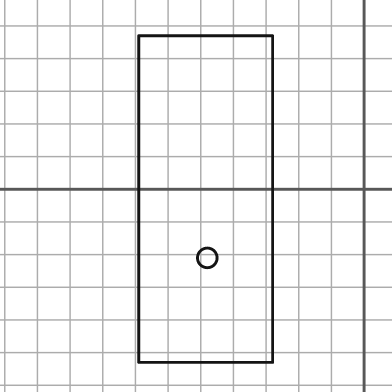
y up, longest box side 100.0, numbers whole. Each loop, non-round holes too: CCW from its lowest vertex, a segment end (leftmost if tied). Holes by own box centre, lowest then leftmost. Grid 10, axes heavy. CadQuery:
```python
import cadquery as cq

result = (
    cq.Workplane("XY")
    .moveTo(-69.0, -53.0)
    .lineTo(-28.0, -53.0)
    .lineTo(-28.0, 47.0)
    .lineTo(-69.0, 47.0)
    .close()
    .moveTo(-48.0, -21.0)
    .circle(3.0)
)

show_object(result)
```